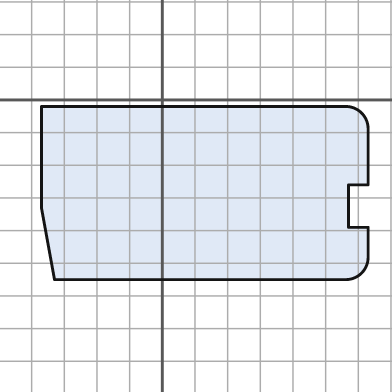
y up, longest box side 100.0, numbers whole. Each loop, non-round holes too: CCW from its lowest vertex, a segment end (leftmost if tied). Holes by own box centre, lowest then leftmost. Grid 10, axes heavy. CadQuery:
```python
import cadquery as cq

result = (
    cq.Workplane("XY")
    .moveTo(-33.0, -55.0)
    .lineTo(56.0, -55.0)
    .threePointArc((61.0, -53.0), (63.0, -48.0))
    .lineTo(63.0, -39.0)
    .lineTo(57.0, -39.0)
    .lineTo(57.0, -26.0)
    .lineTo(63.0, -26.0)
    .lineTo(63.0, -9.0)
    .threePointArc((61.0, -4.0), (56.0, -2.0))
    .lineTo(-37.0, -2.0)
    .lineTo(-37.0, -33.0)
    .close()
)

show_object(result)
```